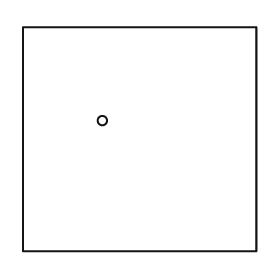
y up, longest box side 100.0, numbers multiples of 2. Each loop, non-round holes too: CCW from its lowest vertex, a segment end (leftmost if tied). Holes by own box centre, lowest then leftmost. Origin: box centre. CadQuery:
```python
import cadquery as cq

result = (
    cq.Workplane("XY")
    .moveTo(-50.0, -48.0)
    .lineTo(50.0, -48.0)
    .lineTo(50.0, 48.0)
    .lineTo(-50.0, 48.0)
    .close()
    .moveTo(-16.0, 8.0)
    .circle(2.0)
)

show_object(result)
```